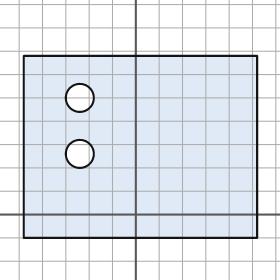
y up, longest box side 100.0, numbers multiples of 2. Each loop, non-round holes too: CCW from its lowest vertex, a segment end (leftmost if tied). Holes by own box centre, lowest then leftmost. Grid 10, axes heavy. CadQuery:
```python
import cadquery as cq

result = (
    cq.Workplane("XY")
    .moveTo(-48.0, -10.0)
    .lineTo(52.0, -10.0)
    .lineTo(52.0, 68.0)
    .lineTo(-48.0, 68.0)
    .close()
    .moveTo(-24.0, 26.0)
    .circle(6.0)
    .moveTo(-24.0, 50.0)
    .circle(6.0)
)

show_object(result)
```